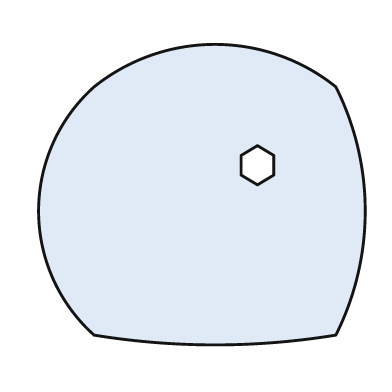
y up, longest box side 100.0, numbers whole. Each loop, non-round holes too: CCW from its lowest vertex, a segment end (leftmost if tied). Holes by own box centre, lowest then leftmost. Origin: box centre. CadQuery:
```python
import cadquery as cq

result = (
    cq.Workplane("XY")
    .moveTo(-33.0, -43.0)
    .threePointArc((4.0, -46.0), (41.0, -43.0))
    .threePointArc((50.0, -5.0), (41.0, 33.0))
    .threePointArc((4.0, 46.0), (-33.0, 33.0))
    .threePointArc((-50.0, -5.0), (-33.0, -43.0))
    .close()
    .moveTo(17.0, 3.0)
    .lineTo(22.0, 6.0)
    .lineTo(22.0, 12.0)
    .lineTo(17.0, 15.0)
    .lineTo(12.0, 12.0)
    .lineTo(12.0, 6.0)
    .close()
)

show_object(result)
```